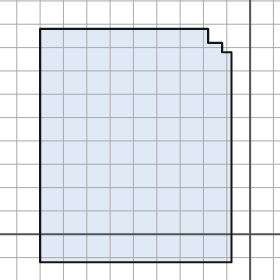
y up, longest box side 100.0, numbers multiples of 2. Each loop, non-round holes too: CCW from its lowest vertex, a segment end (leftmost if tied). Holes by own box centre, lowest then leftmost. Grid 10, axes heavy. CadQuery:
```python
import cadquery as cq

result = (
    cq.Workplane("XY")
    .moveTo(-90.0, -12.0)
    .lineTo(-8.0, -12.0)
    .lineTo(-8.0, 78.0)
    .lineTo(-12.0, 78.0)
    .lineTo(-12.0, 82.0)
    .lineTo(-18.0, 82.0)
    .lineTo(-18.0, 88.0)
    .lineTo(-90.0, 88.0)
    .close()
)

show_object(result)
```